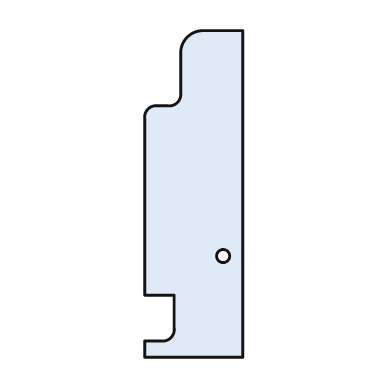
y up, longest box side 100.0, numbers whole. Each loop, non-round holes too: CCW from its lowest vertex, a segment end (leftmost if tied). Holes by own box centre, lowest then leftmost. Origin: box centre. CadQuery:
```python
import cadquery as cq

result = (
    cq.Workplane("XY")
    .moveTo(-15.0, -50.0)
    .lineTo(15.0, -50.0)
    .lineTo(15.0, 50.0)
    .lineTo(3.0, 50.0)
    .threePointArc((-2.0, 48.0), (-4.0, 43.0))
    .lineTo(-4.0, 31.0)
    .threePointArc((-5.0, 28.0), (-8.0, 27.0))
    .lineTo(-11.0, 27.0)
    .threePointArc((-14.0, 26.0), (-15.0, 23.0))
    .lineTo(-15.0, -31.0)
    .lineTo(-6.0, -31.0)
    .lineTo(-6.0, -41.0)
    .threePointArc((-7.0, -44.0), (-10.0, -45.0))
    .lineTo(-15.0, -45.0)
    .close()
    .moveTo(9.0, -19.0)
    .circle(2.0)
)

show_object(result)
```